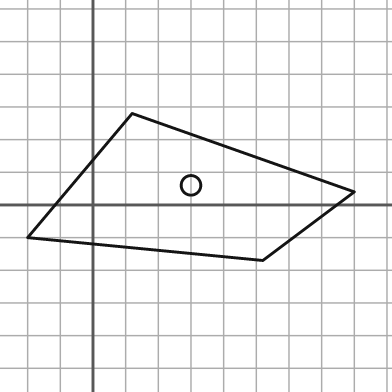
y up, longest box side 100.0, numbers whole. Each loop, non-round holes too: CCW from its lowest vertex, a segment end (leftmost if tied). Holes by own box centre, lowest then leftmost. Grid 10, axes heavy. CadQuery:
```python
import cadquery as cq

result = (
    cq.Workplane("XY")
    .moveTo(52.0, -17.0)
    .lineTo(80.0, 4.0)
    .lineTo(12.0, 28.0)
    .lineTo(-20.0, -10.0)
    .close()
    .moveTo(30.0, 6.0)
    .circle(3.0)
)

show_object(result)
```